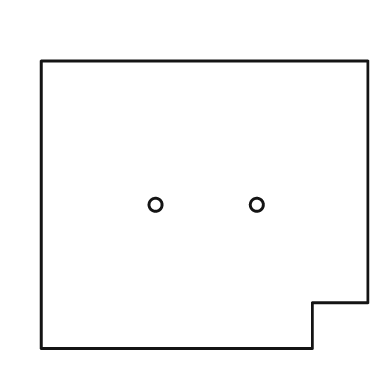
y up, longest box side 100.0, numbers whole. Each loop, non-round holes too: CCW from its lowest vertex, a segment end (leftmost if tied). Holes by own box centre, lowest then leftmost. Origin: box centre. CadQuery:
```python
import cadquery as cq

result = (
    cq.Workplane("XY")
    .moveTo(-50.0, -44.0)
    .lineTo(33.0, -44.0)
    .lineTo(33.0, -30.0)
    .lineTo(50.0, -30.0)
    .lineTo(50.0, 44.0)
    .lineTo(-50.0, 44.0)
    .close()
    .moveTo(-15.0, 0.0)
    .circle(2.0)
    .moveTo(16.0, 0.0)
    .circle(2.0)
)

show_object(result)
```